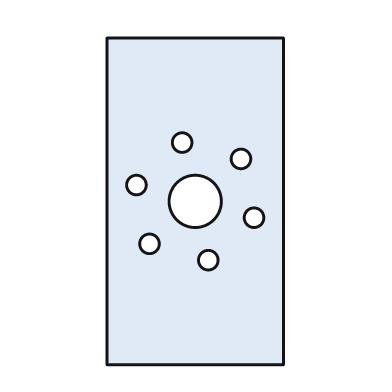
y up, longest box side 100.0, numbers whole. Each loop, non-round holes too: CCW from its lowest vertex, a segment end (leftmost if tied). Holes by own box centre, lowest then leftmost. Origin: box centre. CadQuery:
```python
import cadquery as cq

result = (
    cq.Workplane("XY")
    .moveTo(-27.0, -50.0)
    .lineTo(27.0, -50.0)
    .lineTo(27.0, 50.0)
    .lineTo(-27.0, 50.0)
    .close()
    .moveTo(4.0, -18.0)
    .circle(3.0)
    .moveTo(-14.0, -13.0)
    .circle(3.0)
    .moveTo(18.0, -5.0)
    .circle(3.0)
    .moveTo(0.0, 0.0)
    .circle(8.0)
    .moveTo(-18.0, 5.0)
    .circle(3.0)
    .moveTo(14.0, 13.0)
    .circle(3.0)
    .moveTo(-4.0, 18.0)
    .circle(3.0)
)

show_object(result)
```